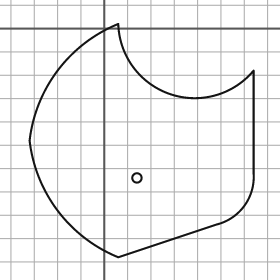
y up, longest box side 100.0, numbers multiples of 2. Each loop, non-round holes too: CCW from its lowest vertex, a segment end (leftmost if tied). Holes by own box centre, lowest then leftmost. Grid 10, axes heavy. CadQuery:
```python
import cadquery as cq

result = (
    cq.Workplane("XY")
    .moveTo(6.0, -98.0)
    .lineTo(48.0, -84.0)
    .threePointArc((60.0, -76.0), (64.0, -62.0))
    .lineTo(64.0, -18.0)
    .threePointArc((28.0, -28.0), (6.0, 2.0))
    .threePointArc((-20.0, -18.0), (-32.0, -48.0))
    .threePointArc((-20.0, -78.0), (6.0, -98.0))
    .close()
    .moveTo(14.0, -64.0)
    .circle(2.0)
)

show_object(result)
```